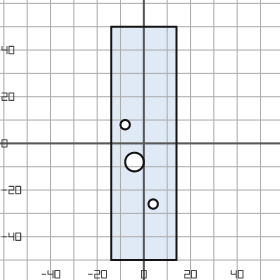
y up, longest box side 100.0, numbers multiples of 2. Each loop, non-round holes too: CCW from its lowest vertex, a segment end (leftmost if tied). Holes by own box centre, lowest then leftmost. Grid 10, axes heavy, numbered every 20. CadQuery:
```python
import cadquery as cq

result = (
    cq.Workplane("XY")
    .moveTo(-14.0, -50.0)
    .lineTo(14.0, -50.0)
    .lineTo(14.0, 50.0)
    .lineTo(-14.0, 50.0)
    .close()
    .moveTo(4.0, -26.0)
    .circle(2.0)
    .moveTo(-4.0, -8.0)
    .circle(4.0)
    .moveTo(-8.0, 8.0)
    .circle(2.0)
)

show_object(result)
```